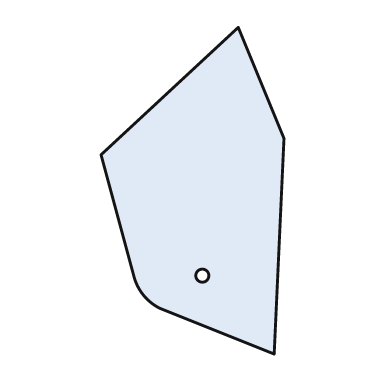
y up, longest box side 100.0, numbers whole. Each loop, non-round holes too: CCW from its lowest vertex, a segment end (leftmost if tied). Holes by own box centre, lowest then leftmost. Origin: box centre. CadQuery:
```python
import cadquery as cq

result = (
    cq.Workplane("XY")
    .moveTo(25.0, -50.0)
    .lineTo(28.0, 16.0)
    .lineTo(14.0, 50.0)
    .lineTo(-28.0, 11.0)
    .lineTo(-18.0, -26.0)
    .threePointArc((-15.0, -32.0), (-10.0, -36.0))
    .close()
    .moveTo(3.0, -26.0)
    .circle(2.0)
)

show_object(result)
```